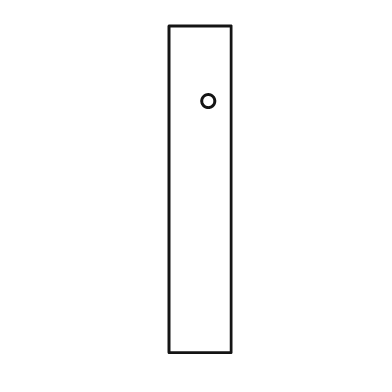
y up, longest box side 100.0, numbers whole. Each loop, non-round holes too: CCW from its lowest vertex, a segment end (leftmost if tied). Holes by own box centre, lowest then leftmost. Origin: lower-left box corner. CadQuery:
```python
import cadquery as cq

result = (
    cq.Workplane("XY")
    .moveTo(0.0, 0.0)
    .lineTo(19.0, 0.0)
    .lineTo(19.0, 100.0)
    .lineTo(0.0, 100.0)
    .close()
    .moveTo(12.0, 77.0)
    .circle(2.0)
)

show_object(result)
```